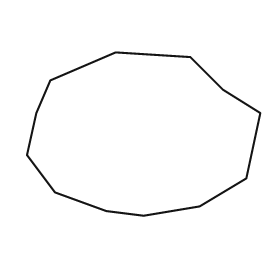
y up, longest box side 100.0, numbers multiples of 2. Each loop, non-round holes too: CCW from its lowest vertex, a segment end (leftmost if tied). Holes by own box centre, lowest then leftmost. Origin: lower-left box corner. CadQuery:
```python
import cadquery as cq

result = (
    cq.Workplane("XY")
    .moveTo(50.0, 0.0)
    .lineTo(74.0, 4.0)
    .lineTo(94.0, 16.0)
    .lineTo(100.0, 44.0)
    .lineTo(84.0, 54.0)
    .lineTo(70.0, 68.0)
    .lineTo(38.0, 70.0)
    .lineTo(10.0, 58.0)
    .lineTo(4.0, 44.0)
    .lineTo(0.0, 26.0)
    .lineTo(12.0, 10.0)
    .lineTo(34.0, 2.0)
    .close()
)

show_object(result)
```